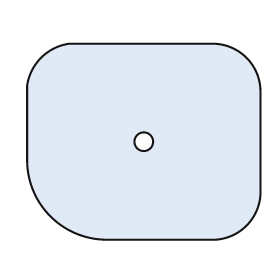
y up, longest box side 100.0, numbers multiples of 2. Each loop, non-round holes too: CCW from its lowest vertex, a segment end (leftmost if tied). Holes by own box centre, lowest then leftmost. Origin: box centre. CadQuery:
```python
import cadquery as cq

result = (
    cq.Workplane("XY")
    .moveTo(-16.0, -42.0)
    .lineTo(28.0, -42.0)
    .threePointArc((44.0, -36.0), (50.0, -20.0))
    .lineTo(50.0, 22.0)
    .threePointArc((44.0, 36.0), (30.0, 42.0))
    .lineTo(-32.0, 42.0)
    .threePointArc((-44.0, 36.0), (-50.0, 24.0))
    .lineTo(-50.0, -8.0)
    .threePointArc((-40.0, -32.0), (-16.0, -42.0))
    .close()
    .moveTo(0.0, 0.0)
    .circle(4.0)
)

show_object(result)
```